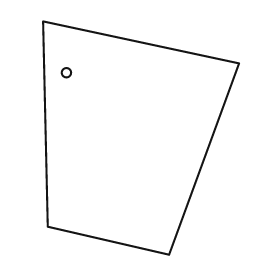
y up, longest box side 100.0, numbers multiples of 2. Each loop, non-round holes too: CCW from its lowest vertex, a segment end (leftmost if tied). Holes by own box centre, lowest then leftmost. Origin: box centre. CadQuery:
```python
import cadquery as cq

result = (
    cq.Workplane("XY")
    .moveTo(12.0, -50.0)
    .lineTo(42.0, 32.0)
    .lineTo(-42.0, 50.0)
    .lineTo(-40.0, -38.0)
    .close()
    .moveTo(-32.0, 28.0)
    .circle(2.0)
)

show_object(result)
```